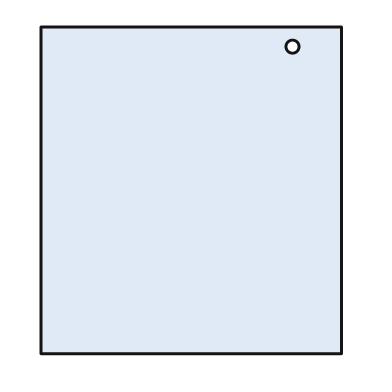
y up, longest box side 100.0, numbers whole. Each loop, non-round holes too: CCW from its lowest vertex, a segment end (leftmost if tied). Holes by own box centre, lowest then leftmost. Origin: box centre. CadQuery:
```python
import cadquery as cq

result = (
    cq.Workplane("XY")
    .moveTo(-46.0, -50.0)
    .lineTo(46.0, -50.0)
    .lineTo(46.0, 50.0)
    .lineTo(-46.0, 50.0)
    .close()
    .moveTo(31.0, 44.0)
    .circle(2.0)
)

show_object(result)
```